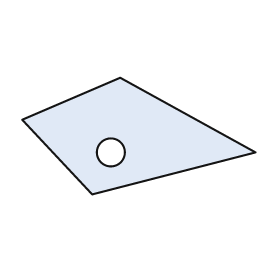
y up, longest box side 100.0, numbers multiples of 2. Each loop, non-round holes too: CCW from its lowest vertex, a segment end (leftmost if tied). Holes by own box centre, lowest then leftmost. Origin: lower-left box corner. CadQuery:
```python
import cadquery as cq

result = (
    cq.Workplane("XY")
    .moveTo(30.0, 0.0)
    .lineTo(100.0, 18.0)
    .lineTo(42.0, 50.0)
    .lineTo(0.0, 32.0)
    .close()
    .moveTo(38.0, 18.0)
    .circle(6.0)
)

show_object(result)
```